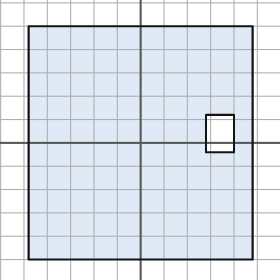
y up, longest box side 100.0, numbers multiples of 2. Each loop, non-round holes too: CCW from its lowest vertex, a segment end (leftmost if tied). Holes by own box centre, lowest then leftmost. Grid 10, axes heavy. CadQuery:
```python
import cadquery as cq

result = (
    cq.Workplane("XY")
    .moveTo(-48.0, -50.0)
    .lineTo(48.0, -50.0)
    .lineTo(48.0, 50.0)
    .lineTo(-48.0, 50.0)
    .close()
    .moveTo(28.0, -4.0)
    .lineTo(40.0, -4.0)
    .lineTo(40.0, 12.0)
    .lineTo(28.0, 12.0)
    .close()
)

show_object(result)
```